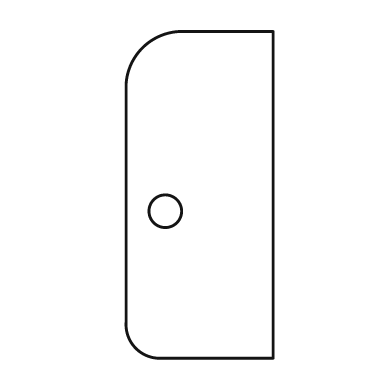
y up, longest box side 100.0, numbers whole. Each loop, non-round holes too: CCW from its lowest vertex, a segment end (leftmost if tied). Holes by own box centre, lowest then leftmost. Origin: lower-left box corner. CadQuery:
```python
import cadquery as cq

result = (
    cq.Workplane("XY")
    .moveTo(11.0, 0.0)
    .lineTo(45.0, 0.0)
    .lineTo(45.0, 100.0)
    .lineTo(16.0, 100.0)
    .threePointArc((5.0, 95.0), (0.0, 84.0))
    .lineTo(0.0, 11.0)
    .threePointArc((3.0, 3.0), (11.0, 0.0))
    .close()
    .moveTo(12.0, 45.0)
    .circle(5.0)
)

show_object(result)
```